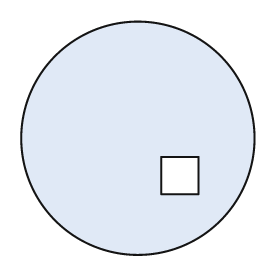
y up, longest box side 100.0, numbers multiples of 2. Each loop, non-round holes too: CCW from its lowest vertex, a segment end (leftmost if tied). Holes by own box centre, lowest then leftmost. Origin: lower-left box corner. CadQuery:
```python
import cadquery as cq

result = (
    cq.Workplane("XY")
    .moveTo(50.0, 50.0)
    .circle(50.0)
    .moveTo(60.0, 26.0)
    .lineTo(76.0, 26.0)
    .lineTo(76.0, 42.0)
    .lineTo(60.0, 42.0)
    .close()
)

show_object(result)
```